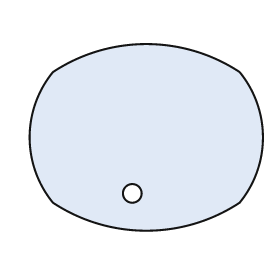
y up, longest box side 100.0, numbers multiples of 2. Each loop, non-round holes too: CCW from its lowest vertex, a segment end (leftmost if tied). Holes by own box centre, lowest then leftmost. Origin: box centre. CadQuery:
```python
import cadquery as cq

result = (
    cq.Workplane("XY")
    .moveTo(-40.0, -28.0)
    .threePointArc((0.0, -40.0), (40.0, -28.0))
    .threePointArc((50.0, 0.0), (40.0, 28.0))
    .threePointArc((0.0, 40.0), (-40.0, 28.0))
    .threePointArc((-50.0, 0.0), (-40.0, -28.0))
    .close()
    .moveTo(-6.0, -24.0)
    .circle(4.0)
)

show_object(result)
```